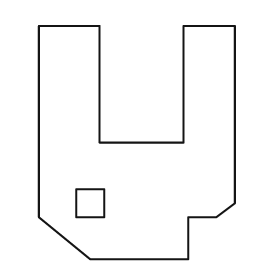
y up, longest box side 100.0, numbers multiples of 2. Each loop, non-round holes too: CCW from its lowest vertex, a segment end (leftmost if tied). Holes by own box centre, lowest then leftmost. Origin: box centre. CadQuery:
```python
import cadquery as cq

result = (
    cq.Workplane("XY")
    .moveTo(-20.0, -50.0)
    .lineTo(22.0, -50.0)
    .lineTo(22.0, -32.0)
    .lineTo(34.0, -32.0)
    .lineTo(42.0, -26.0)
    .lineTo(42.0, 50.0)
    .lineTo(20.0, 50.0)
    .lineTo(20.0, 0.0)
    .lineTo(-16.0, 0.0)
    .lineTo(-16.0, 50.0)
    .lineTo(-42.0, 50.0)
    .lineTo(-42.0, -32.0)
    .close()
    .moveTo(-26.0, -32.0)
    .lineTo(-14.0, -32.0)
    .lineTo(-14.0, -20.0)
    .lineTo(-26.0, -20.0)
    .close()
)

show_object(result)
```